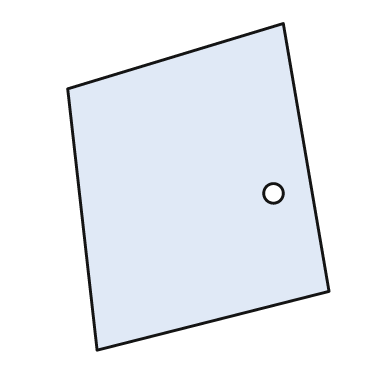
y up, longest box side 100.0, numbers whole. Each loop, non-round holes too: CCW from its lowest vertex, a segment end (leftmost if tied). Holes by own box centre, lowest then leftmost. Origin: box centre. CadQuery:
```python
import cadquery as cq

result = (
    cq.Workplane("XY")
    .moveTo(-31.0, -50.0)
    .lineTo(40.0, -32.0)
    .lineTo(26.0, 50.0)
    .lineTo(-40.0, 30.0)
    .close()
    .moveTo(23.0, -2.0)
    .circle(3.0)
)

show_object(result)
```